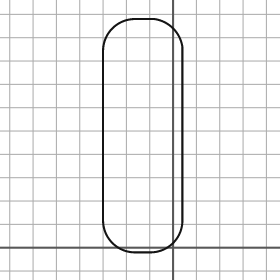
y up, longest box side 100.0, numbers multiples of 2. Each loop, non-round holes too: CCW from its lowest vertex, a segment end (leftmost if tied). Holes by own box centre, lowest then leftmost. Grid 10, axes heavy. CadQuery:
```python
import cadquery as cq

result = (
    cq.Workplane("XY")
    .moveTo(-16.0, -2.0)
    .lineTo(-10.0, -2.0)
    .threePointArc((0.0, 2.0), (4.0, 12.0))
    .lineTo(4.0, 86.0)
    .threePointArc((0.0, 94.0), (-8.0, 98.0))
    .lineTo(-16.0, 98.0)
    .threePointArc((-26.0, 94.0), (-30.0, 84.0))
    .lineTo(-30.0, 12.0)
    .threePointArc((-26.0, 2.0), (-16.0, -2.0))
    .close()
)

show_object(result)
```